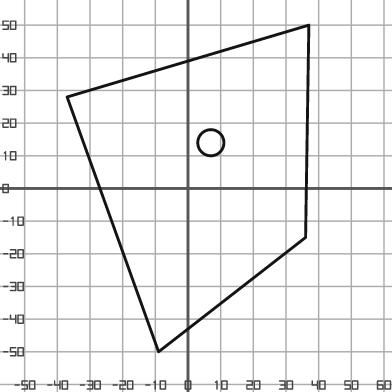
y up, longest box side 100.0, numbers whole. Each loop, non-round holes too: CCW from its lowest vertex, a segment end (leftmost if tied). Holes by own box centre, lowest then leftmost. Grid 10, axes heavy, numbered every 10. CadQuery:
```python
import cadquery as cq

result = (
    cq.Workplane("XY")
    .moveTo(-9.0, -50.0)
    .lineTo(36.0, -15.0)
    .lineTo(37.0, 50.0)
    .lineTo(-37.0, 28.0)
    .close()
    .moveTo(7.0, 14.0)
    .circle(4.0)
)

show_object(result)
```